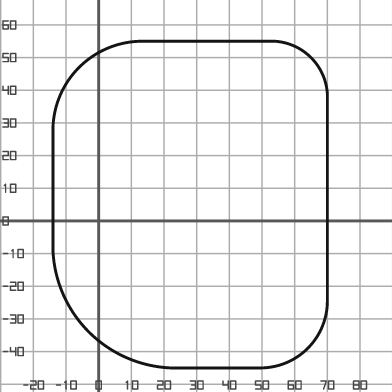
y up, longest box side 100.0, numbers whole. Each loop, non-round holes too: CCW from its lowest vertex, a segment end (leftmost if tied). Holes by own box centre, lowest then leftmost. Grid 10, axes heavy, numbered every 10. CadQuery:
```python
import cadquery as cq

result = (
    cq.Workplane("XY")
    .moveTo(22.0, -45.0)
    .lineTo(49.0, -45.0)
    .threePointArc((64.0, -39.0), (70.0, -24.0))
    .lineTo(70.0, 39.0)
    .threePointArc((65.0, 50.0), (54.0, 55.0))
    .lineTo(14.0, 55.0)
    .threePointArc((-6.0, 47.0), (-14.0, 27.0))
    .lineTo(-14.0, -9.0)
    .threePointArc((-3.0, -34.0), (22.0, -45.0))
    .close()
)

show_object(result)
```